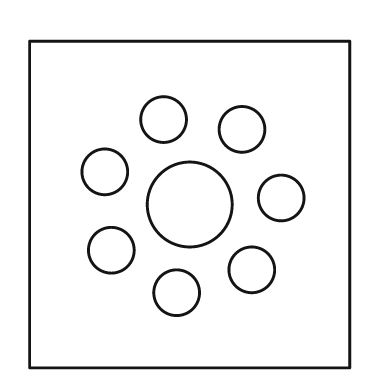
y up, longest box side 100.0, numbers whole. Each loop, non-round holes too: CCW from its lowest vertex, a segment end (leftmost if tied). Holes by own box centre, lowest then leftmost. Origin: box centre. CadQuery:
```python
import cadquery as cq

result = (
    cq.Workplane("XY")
    .moveTo(-49.0, -50.0)
    .lineTo(49.0, -50.0)
    .lineTo(49.0, 50.0)
    .lineTo(-49.0, 50.0)
    .close()
    .moveTo(-4.0, -27.0)
    .circle(7.0)
    .moveTo(19.0, -20.0)
    .circle(7.0)
    .moveTo(-24.0, -14.0)
    .circle(7.0)
    .moveTo(0.0, 0.0)
    .circle(13.0)
    .moveTo(28.0, 2.0)
    .circle(7.0)
    .moveTo(-26.0, 10.0)
    .circle(7.0)
    .moveTo(16.0, 23.0)
    .circle(7.0)
    .moveTo(-8.0, 26.0)
    .circle(7.0)
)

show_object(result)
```